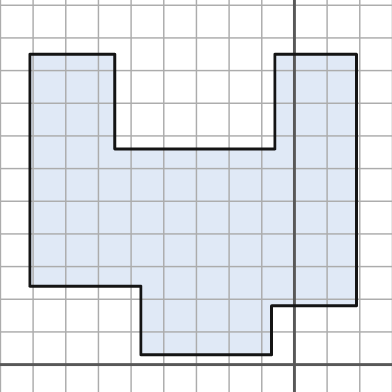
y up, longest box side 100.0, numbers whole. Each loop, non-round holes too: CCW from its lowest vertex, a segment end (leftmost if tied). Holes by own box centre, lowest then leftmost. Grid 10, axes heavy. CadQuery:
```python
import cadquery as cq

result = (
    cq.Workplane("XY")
    .moveTo(-47.0, 3.0)
    .lineTo(-7.0, 3.0)
    .lineTo(-7.0, 18.0)
    .lineTo(19.0, 18.0)
    .lineTo(19.0, 95.0)
    .lineTo(-6.0, 95.0)
    .lineTo(-6.0, 66.0)
    .lineTo(-55.0, 66.0)
    .lineTo(-55.0, 95.0)
    .lineTo(-81.0, 95.0)
    .lineTo(-81.0, 24.0)
    .lineTo(-47.0, 24.0)
    .close()
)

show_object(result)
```